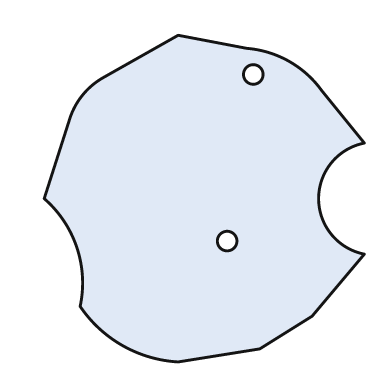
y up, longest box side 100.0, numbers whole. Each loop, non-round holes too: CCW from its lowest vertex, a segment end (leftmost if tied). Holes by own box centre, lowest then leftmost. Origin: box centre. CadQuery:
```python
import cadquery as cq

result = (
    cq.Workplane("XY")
    .moveTo(-8.0, -50.0)
    .lineTo(17.0, -46.0)
    .lineTo(33.0, -36.0)
    .lineTo(49.0, -17.0)
    .threePointArc((35.0, 0.0), (49.0, 17.0))
    .lineTo(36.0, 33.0)
    .threePointArc((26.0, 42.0), (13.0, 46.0))
    .lineTo(-8.0, 50.0)
    .lineTo(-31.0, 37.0)
    .threePointArc((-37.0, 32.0), (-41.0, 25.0))
    .lineTo(-49.0, 0.0)
    .threePointArc((-39.0, -15.0), (-38.0, -33.0))
    .threePointArc((-25.0, -45.0), (-8.0, -50.0))
    .close()
    .moveTo(7.0, -13.0)
    .circle(3.0)
    .moveTo(15.0, 38.0)
    .circle(3.0)
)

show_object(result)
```